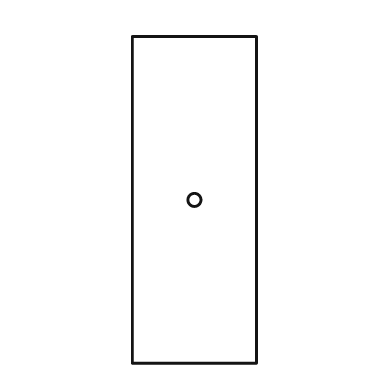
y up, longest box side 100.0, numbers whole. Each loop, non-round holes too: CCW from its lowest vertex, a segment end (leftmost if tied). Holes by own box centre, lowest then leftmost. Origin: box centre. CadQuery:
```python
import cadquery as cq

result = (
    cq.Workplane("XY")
    .moveTo(-19.0, -50.0)
    .lineTo(19.0, -50.0)
    .lineTo(19.0, 50.0)
    .lineTo(-19.0, 50.0)
    .close()
    .moveTo(0.0, 0.0)
    .circle(2.0)
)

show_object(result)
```